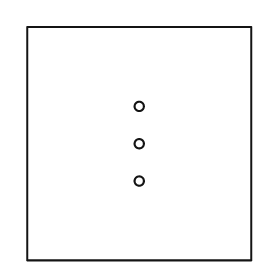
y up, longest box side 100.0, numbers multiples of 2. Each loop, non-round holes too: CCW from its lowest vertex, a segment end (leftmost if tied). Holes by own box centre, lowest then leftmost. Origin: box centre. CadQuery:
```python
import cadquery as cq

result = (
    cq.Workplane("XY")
    .moveTo(-48.0, -50.0)
    .lineTo(48.0, -50.0)
    .lineTo(48.0, 50.0)
    .lineTo(-48.0, 50.0)
    .close()
    .moveTo(0.0, -16.0)
    .circle(2.0)
    .moveTo(0.0, 0.0)
    .circle(2.0)
    .moveTo(0.0, 16.0)
    .circle(2.0)
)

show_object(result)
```